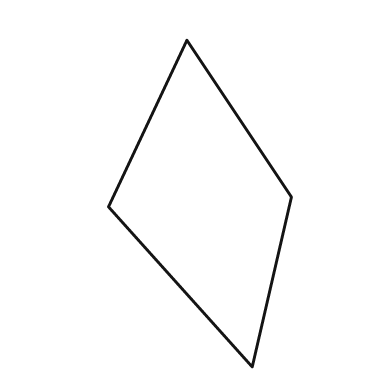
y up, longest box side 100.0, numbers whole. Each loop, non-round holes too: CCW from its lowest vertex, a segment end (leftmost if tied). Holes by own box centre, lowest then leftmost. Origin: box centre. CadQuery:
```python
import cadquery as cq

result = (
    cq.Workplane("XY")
    .moveTo(16.0, -50.0)
    .lineTo(28.0, 2.0)
    .lineTo(-4.0, 50.0)
    .lineTo(-28.0, -1.0)
    .close()
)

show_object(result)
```